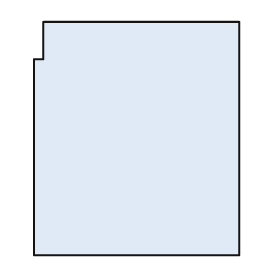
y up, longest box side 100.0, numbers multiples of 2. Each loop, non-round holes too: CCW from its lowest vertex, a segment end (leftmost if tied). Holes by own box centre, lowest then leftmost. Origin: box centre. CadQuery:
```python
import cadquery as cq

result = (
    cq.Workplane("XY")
    .moveTo(-44.0, -50.0)
    .lineTo(44.0, -50.0)
    .lineTo(44.0, 50.0)
    .lineTo(-40.0, 50.0)
    .lineTo(-40.0, 34.0)
    .lineTo(-44.0, 34.0)
    .close()
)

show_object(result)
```